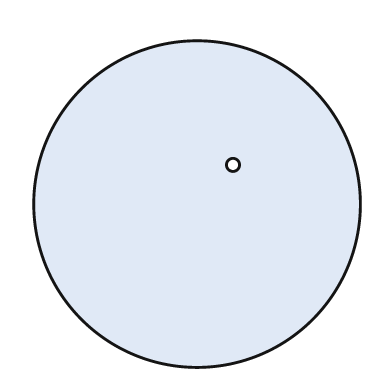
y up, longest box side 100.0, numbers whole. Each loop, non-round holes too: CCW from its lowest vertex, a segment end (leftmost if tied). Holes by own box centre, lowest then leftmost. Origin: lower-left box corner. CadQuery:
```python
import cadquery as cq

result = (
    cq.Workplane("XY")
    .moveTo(50.0, 50.0)
    .circle(50.0)
    .moveTo(61.0, 62.0)
    .circle(2.0)
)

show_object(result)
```